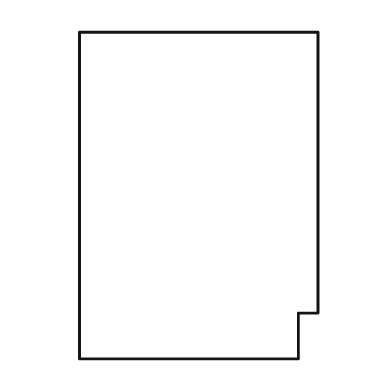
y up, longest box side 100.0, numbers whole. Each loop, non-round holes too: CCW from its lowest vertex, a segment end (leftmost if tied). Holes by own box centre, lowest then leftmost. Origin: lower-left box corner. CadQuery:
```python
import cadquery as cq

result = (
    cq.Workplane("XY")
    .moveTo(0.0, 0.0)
    .lineTo(67.0, 0.0)
    .lineTo(67.0, 14.0)
    .lineTo(73.0, 14.0)
    .lineTo(73.0, 100.0)
    .lineTo(0.0, 100.0)
    .close()
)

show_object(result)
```